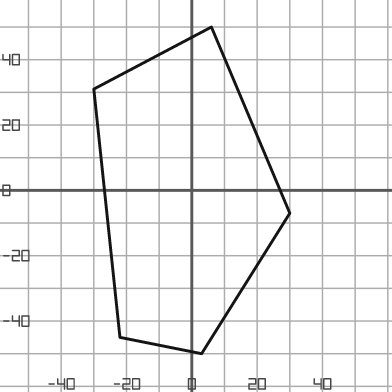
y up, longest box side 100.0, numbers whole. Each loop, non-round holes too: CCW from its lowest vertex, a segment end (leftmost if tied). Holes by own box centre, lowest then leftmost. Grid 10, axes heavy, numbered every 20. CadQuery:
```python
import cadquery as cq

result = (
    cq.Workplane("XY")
    .moveTo(3.0, -50.0)
    .lineTo(30.0, -7.0)
    .lineTo(6.0, 50.0)
    .lineTo(-30.0, 31.0)
    .lineTo(-22.0, -45.0)
    .close()
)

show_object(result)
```